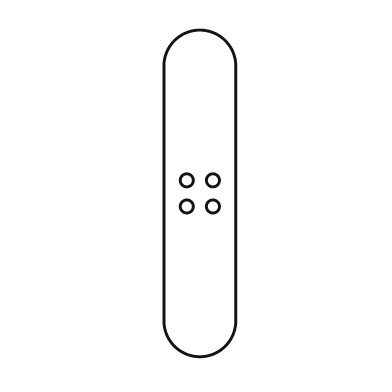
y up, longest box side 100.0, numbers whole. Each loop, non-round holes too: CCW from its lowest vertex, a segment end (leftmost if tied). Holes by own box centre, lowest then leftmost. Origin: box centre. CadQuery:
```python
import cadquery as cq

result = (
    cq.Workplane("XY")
    .moveTo(-11.0, -39.0)
    .threePointArc((0.0, -50.0), (11.0, -39.0))
    .lineTo(11.0, 39.0)
    .threePointArc((0.0, 50.0), (-11.0, 39.0))
    .close()
    .moveTo(-4.0, -4.0)
    .circle(2.0)
    .moveTo(4.0, -4.0)
    .circle(2.0)
    .moveTo(-4.0, 4.0)
    .circle(2.0)
    .moveTo(4.0, 4.0)
    .circle(2.0)
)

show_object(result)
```